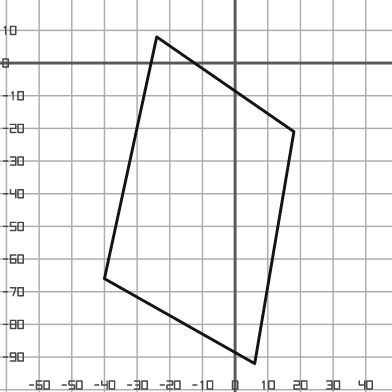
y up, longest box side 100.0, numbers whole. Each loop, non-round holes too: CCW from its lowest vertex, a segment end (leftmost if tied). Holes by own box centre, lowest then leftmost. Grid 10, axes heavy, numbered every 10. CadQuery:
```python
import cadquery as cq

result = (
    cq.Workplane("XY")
    .moveTo(6.0, -92.0)
    .lineTo(18.0, -21.0)
    .lineTo(-24.0, 8.0)
    .lineTo(-40.0, -66.0)
    .close()
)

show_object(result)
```